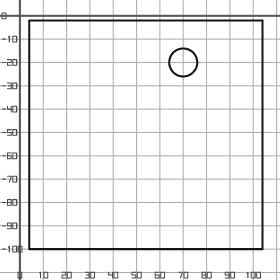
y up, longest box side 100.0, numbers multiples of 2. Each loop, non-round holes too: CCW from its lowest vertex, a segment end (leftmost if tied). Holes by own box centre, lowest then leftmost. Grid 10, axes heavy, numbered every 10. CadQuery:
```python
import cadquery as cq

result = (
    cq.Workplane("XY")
    .moveTo(4.0, -100.0)
    .lineTo(104.0, -100.0)
    .lineTo(104.0, -2.0)
    .lineTo(4.0, -2.0)
    .close()
    .moveTo(70.0, -20.0)
    .circle(6.0)
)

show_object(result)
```